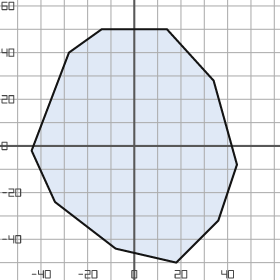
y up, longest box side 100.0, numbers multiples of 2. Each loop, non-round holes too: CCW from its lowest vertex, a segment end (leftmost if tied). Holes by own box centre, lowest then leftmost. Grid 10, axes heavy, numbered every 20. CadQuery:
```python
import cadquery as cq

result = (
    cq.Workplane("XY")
    .moveTo(18.0, -50.0)
    .lineTo(36.0, -32.0)
    .lineTo(44.0, -8.0)
    .lineTo(34.0, 28.0)
    .lineTo(14.0, 50.0)
    .lineTo(-14.0, 50.0)
    .lineTo(-28.0, 40.0)
    .lineTo(-44.0, -2.0)
    .lineTo(-34.0, -24.0)
    .lineTo(-8.0, -44.0)
    .close()
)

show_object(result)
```